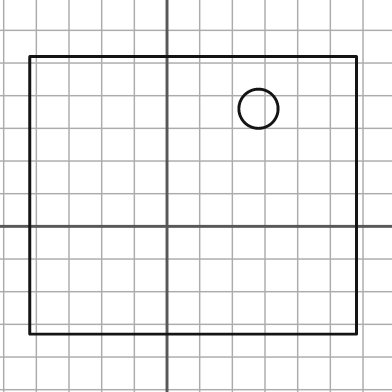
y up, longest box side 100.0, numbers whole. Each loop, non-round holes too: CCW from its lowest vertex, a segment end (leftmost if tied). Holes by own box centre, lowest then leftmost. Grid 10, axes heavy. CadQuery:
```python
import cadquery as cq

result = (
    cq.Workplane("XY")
    .moveTo(-42.0, -33.0)
    .lineTo(58.0, -33.0)
    .lineTo(58.0, 52.0)
    .lineTo(-42.0, 52.0)
    .close()
    .moveTo(28.0, 36.0)
    .circle(6.0)
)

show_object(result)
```